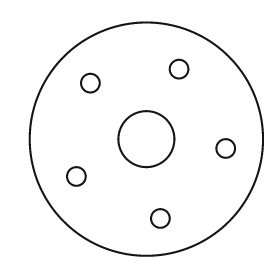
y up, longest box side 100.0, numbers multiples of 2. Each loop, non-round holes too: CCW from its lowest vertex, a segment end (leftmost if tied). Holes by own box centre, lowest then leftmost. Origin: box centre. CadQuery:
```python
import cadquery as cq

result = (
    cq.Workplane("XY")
    .moveTo(0.0, 0.0)
    .circle(50.0)
    .moveTo(6.0, -34.0)
    .circle(4.0)
    .moveTo(-30.0, -16.0)
    .circle(4.0)
    .moveTo(34.0, -4.0)
    .circle(4.0)
    .moveTo(0.0, 0.0)
    .circle(12.0)
    .moveTo(-24.0, 24.0)
    .circle(4.0)
    .moveTo(14.0, 30.0)
    .circle(4.0)
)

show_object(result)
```